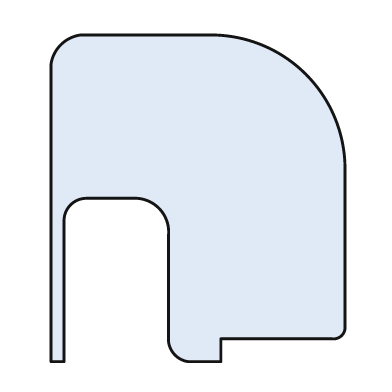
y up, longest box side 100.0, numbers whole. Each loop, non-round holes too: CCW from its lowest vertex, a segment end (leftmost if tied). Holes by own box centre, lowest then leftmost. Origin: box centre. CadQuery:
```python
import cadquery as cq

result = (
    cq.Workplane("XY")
    .moveTo(-45.0, -50.0)
    .lineTo(-41.0, -50.0)
    .lineTo(-41.0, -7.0)
    .threePointArc((-39.0, -2.0), (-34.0, 0.0))
    .lineTo(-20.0, 0.0)
    .threePointArc((-12.0, -3.0), (-9.0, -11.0))
    .lineTo(-9.0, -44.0)
    .threePointArc((-7.0, -48.0), (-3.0, -50.0))
    .lineTo(7.0, -50.0)
    .lineTo(7.0, -43.0)
    .lineTo(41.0, -43.0)
    .threePointArc((44.0, -42.0), (45.0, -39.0))
    .lineTo(45.0, 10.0)
    .threePointArc((33.0, 38.0), (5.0, 50.0))
    .lineTo(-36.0, 50.0)
    .threePointArc((-42.0, 47.0), (-45.0, 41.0))
    .close()
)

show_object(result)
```